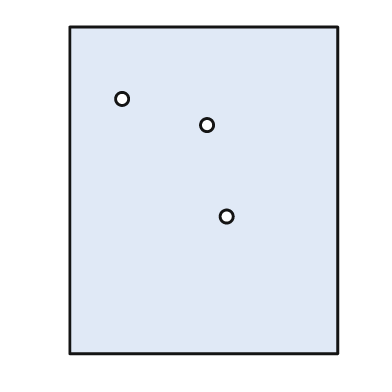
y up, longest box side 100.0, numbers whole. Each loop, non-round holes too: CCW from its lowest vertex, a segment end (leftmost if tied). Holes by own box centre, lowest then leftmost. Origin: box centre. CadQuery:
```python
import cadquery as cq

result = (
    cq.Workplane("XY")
    .moveTo(-41.0, -50.0)
    .lineTo(41.0, -50.0)
    .lineTo(41.0, 50.0)
    .lineTo(-41.0, 50.0)
    .close()
    .moveTo(7.0, -8.0)
    .circle(2.0)
    .moveTo(1.0, 20.0)
    .circle(2.0)
    .moveTo(-25.0, 28.0)
    .circle(2.0)
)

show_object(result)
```